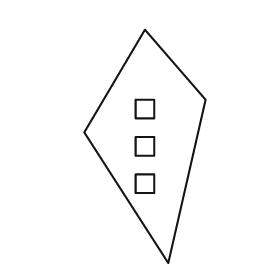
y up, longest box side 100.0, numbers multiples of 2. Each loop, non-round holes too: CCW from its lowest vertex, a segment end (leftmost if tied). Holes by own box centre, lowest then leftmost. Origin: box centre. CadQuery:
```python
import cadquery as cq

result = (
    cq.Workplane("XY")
    .moveTo(10.0, -50.0)
    .lineTo(26.0, 20.0)
    .lineTo(0.0, 50.0)
    .lineTo(-26.0, 6.0)
    .close()
    .moveTo(-4.0, -20.0)
    .lineTo(4.0, -20.0)
    .lineTo(4.0, -12.0)
    .lineTo(-4.0, -12.0)
    .close()
    .moveTo(-4.0, -4.0)
    .lineTo(4.0, -4.0)
    .lineTo(4.0, 4.0)
    .lineTo(-4.0, 4.0)
    .close()
    .moveTo(-4.0, 12.0)
    .lineTo(4.0, 12.0)
    .lineTo(4.0, 20.0)
    .lineTo(-4.0, 20.0)
    .close()
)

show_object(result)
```